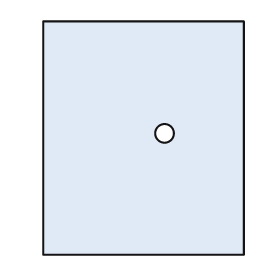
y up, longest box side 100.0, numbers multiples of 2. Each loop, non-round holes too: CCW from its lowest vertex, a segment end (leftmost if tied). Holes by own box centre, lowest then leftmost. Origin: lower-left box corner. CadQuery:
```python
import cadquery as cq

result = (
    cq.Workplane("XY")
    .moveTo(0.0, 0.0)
    .lineTo(86.0, 0.0)
    .lineTo(86.0, 100.0)
    .lineTo(0.0, 100.0)
    .close()
    .moveTo(52.0, 52.0)
    .circle(4.0)
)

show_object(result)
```